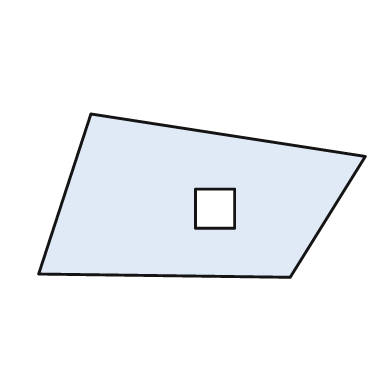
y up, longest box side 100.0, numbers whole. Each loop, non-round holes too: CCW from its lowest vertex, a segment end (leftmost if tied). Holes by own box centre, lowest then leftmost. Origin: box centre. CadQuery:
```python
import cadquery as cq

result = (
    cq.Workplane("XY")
    .moveTo(27.0, -25.0)
    .lineTo(50.0, 12.0)
    .lineTo(-34.0, 25.0)
    .lineTo(-50.0, -24.0)
    .close()
    .moveTo(-2.0, -10.0)
    .lineTo(10.0, -10.0)
    .lineTo(10.0, 2.0)
    .lineTo(-2.0, 2.0)
    .close()
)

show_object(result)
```